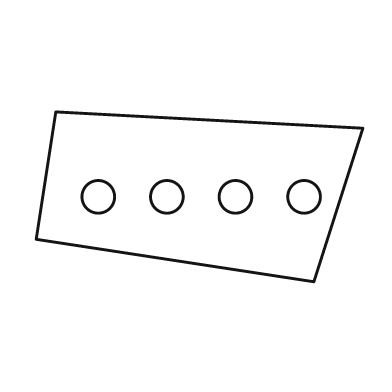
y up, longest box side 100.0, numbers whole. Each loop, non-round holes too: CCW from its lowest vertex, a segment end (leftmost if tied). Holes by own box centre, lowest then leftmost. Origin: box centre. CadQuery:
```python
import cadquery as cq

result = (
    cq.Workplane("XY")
    .moveTo(35.0, -26.0)
    .lineTo(50.0, 21.0)
    .lineTo(-44.0, 26.0)
    .lineTo(-50.0, -13.0)
    .close()
    .moveTo(-31.0, 0.0)
    .circle(5.0)
    .moveTo(-10.0, 0.0)
    .circle(5.0)
    .moveTo(11.0, 0.0)
    .circle(5.0)
    .moveTo(32.0, 0.0)
    .circle(5.0)
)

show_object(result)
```